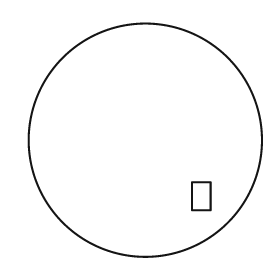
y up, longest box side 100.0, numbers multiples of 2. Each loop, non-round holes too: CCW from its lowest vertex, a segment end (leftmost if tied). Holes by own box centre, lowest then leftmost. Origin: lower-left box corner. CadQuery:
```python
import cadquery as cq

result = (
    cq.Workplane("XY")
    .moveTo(50.0, 50.0)
    .circle(50.0)
    .moveTo(70.0, 20.0)
    .lineTo(78.0, 20.0)
    .lineTo(78.0, 32.0)
    .lineTo(70.0, 32.0)
    .close()
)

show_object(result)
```